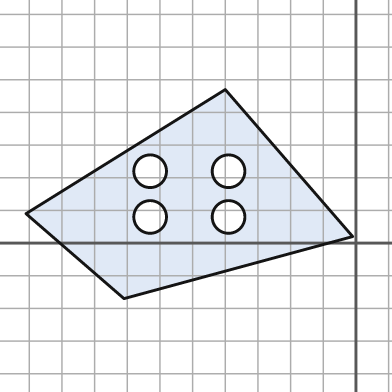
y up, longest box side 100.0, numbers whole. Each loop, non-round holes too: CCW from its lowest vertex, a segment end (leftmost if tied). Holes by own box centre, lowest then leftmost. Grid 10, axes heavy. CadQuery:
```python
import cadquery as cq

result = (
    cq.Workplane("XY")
    .moveTo(-71.0, -17.0)
    .lineTo(-1.0, 2.0)
    .lineTo(-40.0, 47.0)
    .lineTo(-101.0, 9.0)
    .close()
    .moveTo(-63.0, 8.0)
    .circle(5.0)
    .moveTo(-39.0, 8.0)
    .circle(5.0)
    .moveTo(-63.0, 22.0)
    .circle(5.0)
    .moveTo(-39.0, 22.0)
    .circle(5.0)
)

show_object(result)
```